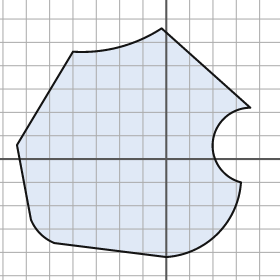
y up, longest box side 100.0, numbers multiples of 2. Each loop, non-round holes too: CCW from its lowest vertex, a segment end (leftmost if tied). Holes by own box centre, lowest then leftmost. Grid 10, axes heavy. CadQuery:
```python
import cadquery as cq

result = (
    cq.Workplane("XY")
    .moveTo(0.0, -42.0)
    .threePointArc((22.0, -32.0), (32.0, -10.0))
    .threePointArc((20.0, 8.0), (36.0, 22.0))
    .lineTo(-2.0, 56.0)
    .threePointArc((-20.0, 48.0), (-40.0, 46.0))
    .lineTo(-64.0, 6.0)
    .lineTo(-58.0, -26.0)
    .threePointArc((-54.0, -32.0), (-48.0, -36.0))
    .close()
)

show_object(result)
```